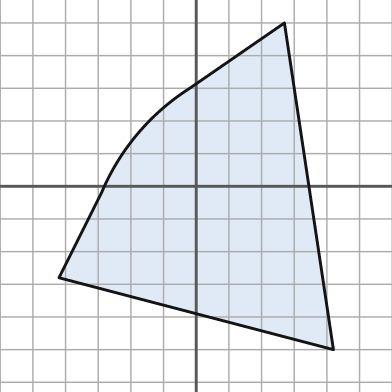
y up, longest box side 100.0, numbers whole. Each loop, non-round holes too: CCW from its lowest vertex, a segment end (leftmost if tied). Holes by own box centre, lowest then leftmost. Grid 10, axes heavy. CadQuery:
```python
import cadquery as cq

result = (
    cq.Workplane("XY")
    .moveTo(42.0, -50.0)
    .lineTo(27.0, 50.0)
    .lineTo(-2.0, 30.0)
    .threePointArc((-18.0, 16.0), (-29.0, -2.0))
    .lineTo(-42.0, -28.0)
    .close()
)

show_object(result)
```